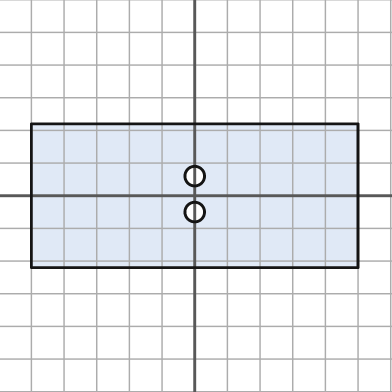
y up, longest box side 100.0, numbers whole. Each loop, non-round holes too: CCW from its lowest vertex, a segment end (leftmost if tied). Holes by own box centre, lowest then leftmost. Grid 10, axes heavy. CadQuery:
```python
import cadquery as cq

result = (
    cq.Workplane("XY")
    .moveTo(-50.0, -22.0)
    .lineTo(50.0, -22.0)
    .lineTo(50.0, 22.0)
    .lineTo(-50.0, 22.0)
    .close()
    .moveTo(0.0, -5.0)
    .circle(3.0)
    .moveTo(0.0, 6.0)
    .circle(3.0)
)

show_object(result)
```